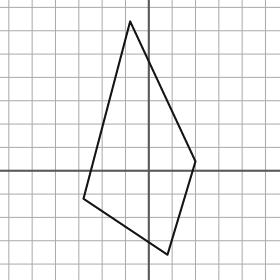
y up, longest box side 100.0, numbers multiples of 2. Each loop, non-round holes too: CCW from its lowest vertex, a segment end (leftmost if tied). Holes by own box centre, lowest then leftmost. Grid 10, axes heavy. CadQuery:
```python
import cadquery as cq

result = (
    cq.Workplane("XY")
    .moveTo(8.0, -36.0)
    .lineTo(20.0, 4.0)
    .lineTo(-8.0, 64.0)
    .lineTo(-28.0, -12.0)
    .close()
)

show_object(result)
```